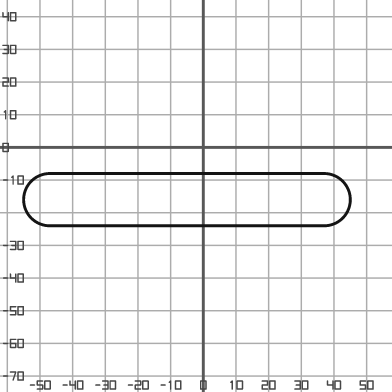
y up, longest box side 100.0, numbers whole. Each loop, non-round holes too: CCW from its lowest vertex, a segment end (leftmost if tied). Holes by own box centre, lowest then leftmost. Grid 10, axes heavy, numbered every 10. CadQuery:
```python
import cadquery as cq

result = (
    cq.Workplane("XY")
    .moveTo(-47.0, -24.0)
    .lineTo(37.0, -24.0)
    .threePointArc((45.0, -16.0), (37.0, -8.0))
    .lineTo(-47.0, -8.0)
    .threePointArc((-55.0, -16.0), (-47.0, -24.0))
    .close()
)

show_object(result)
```